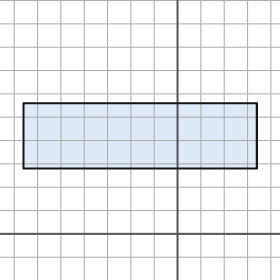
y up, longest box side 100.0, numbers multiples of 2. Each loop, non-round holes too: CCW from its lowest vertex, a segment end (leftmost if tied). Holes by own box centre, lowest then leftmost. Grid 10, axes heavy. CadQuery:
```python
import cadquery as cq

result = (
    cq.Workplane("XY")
    .moveTo(-66.0, 28.0)
    .lineTo(34.0, 28.0)
    .lineTo(34.0, 56.0)
    .lineTo(-66.0, 56.0)
    .close()
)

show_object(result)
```